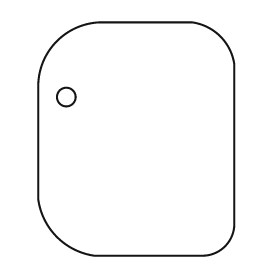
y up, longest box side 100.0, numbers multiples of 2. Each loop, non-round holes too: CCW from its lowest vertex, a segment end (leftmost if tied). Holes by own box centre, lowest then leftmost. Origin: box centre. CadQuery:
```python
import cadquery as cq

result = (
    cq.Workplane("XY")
    .moveTo(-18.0, -50.0)
    .lineTo(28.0, -50.0)
    .threePointArc((38.0, -46.0), (42.0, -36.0))
    .lineTo(42.0, 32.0)
    .threePointArc((36.0, 44.0), (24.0, 50.0))
    .lineTo(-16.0, 50.0)
    .threePointArc((-34.0, 42.0), (-42.0, 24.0))
    .lineTo(-42.0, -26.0)
    .threePointArc((-34.0, -42.0), (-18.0, -50.0))
    .close()
    .moveTo(-30.0, 18.0)
    .circle(4.0)
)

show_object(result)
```